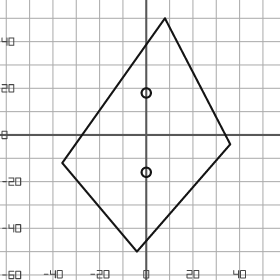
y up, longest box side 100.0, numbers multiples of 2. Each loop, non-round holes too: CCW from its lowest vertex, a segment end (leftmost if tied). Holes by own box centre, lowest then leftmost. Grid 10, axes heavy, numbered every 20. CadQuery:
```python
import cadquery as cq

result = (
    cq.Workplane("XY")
    .moveTo(-4.0, -50.0)
    .lineTo(36.0, -4.0)
    .lineTo(8.0, 50.0)
    .lineTo(-36.0, -12.0)
    .close()
    .moveTo(0.0, -16.0)
    .circle(2.0)
    .moveTo(0.0, 18.0)
    .circle(2.0)
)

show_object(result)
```